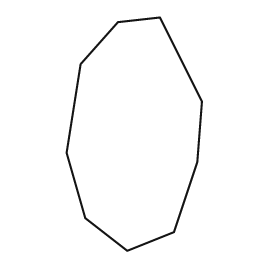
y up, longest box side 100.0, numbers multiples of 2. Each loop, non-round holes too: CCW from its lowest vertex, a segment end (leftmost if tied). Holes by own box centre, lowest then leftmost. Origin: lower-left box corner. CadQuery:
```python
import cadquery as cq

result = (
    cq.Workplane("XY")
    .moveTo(26.0, 0.0)
    .lineTo(46.0, 8.0)
    .lineTo(56.0, 38.0)
    .lineTo(58.0, 64.0)
    .lineTo(40.0, 100.0)
    .lineTo(22.0, 98.0)
    .lineTo(6.0, 80.0)
    .lineTo(0.0, 42.0)
    .lineTo(8.0, 14.0)
    .close()
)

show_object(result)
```